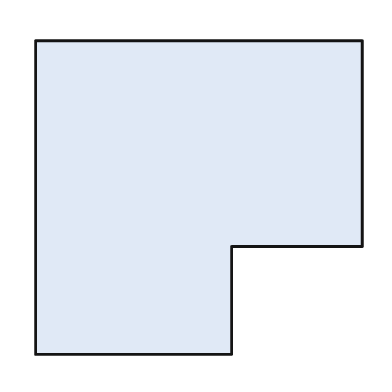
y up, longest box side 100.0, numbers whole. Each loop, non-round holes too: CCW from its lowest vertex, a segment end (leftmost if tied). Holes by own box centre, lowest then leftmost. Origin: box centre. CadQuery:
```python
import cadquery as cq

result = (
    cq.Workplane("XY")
    .moveTo(-50.0, -48.0)
    .lineTo(10.0, -48.0)
    .lineTo(10.0, -15.0)
    .lineTo(50.0, -15.0)
    .lineTo(50.0, 48.0)
    .lineTo(-50.0, 48.0)
    .close()
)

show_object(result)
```